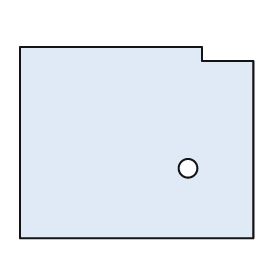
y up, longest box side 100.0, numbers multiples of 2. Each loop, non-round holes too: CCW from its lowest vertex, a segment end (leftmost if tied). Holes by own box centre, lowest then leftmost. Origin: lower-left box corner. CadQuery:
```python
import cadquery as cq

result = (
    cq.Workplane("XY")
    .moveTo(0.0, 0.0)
    .lineTo(100.0, 0.0)
    .lineTo(100.0, 76.0)
    .lineTo(78.0, 76.0)
    .lineTo(78.0, 82.0)
    .lineTo(0.0, 82.0)
    .close()
    .moveTo(72.0, 30.0)
    .circle(4.0)
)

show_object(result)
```